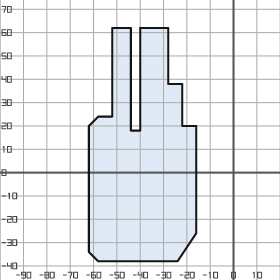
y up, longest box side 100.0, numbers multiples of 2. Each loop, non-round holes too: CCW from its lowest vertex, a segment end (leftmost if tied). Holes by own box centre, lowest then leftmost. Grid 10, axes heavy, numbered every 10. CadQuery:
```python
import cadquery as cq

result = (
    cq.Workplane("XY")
    .moveTo(-58.0, -38.0)
    .lineTo(-24.0, -38.0)
    .lineTo(-16.0, -26.0)
    .lineTo(-16.0, 20.0)
    .lineTo(-22.0, 20.0)
    .lineTo(-22.0, 38.0)
    .lineTo(-28.0, 38.0)
    .lineTo(-28.0, 62.0)
    .lineTo(-40.0, 62.0)
    .lineTo(-40.0, 18.0)
    .lineTo(-44.0, 18.0)
    .lineTo(-44.0, 62.0)
    .lineTo(-52.0, 62.0)
    .lineTo(-52.0, 24.0)
    .lineTo(-58.0, 24.0)
    .lineTo(-62.0, 20.0)
    .lineTo(-62.0, -34.0)
    .close()
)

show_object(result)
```